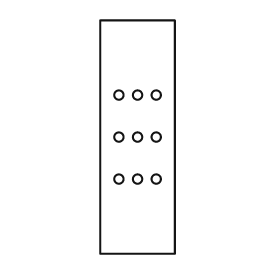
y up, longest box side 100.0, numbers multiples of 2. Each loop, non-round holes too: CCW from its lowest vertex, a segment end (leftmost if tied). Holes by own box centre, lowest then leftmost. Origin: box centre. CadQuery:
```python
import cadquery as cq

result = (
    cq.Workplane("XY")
    .moveTo(-16.0, -50.0)
    .lineTo(16.0, -50.0)
    .lineTo(16.0, 50.0)
    .lineTo(-16.0, 50.0)
    .close()
    .moveTo(-8.0, -18.0)
    .circle(2.0)
    .moveTo(0.0, -18.0)
    .circle(2.0)
    .moveTo(8.0, -18.0)
    .circle(2.0)
    .moveTo(-8.0, 0.0)
    .circle(2.0)
    .moveTo(0.0, 0.0)
    .circle(2.0)
    .moveTo(8.0, 0.0)
    .circle(2.0)
    .moveTo(-8.0, 18.0)
    .circle(2.0)
    .moveTo(0.0, 18.0)
    .circle(2.0)
    .moveTo(8.0, 18.0)
    .circle(2.0)
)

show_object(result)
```